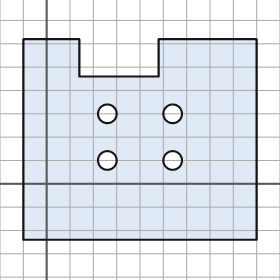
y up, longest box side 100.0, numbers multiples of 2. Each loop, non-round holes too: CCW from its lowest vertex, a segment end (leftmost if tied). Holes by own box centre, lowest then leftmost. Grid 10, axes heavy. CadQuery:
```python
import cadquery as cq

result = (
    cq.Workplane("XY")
    .moveTo(-10.0, -24.0)
    .lineTo(90.0, -24.0)
    .lineTo(90.0, 62.0)
    .lineTo(48.0, 62.0)
    .lineTo(48.0, 46.0)
    .lineTo(14.0, 46.0)
    .lineTo(14.0, 62.0)
    .lineTo(-10.0, 62.0)
    .close()
    .moveTo(26.0, 10.0)
    .circle(4.0)
    .moveTo(54.0, 10.0)
    .circle(4.0)
    .moveTo(26.0, 30.0)
    .circle(4.0)
    .moveTo(54.0, 30.0)
    .circle(4.0)
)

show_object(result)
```